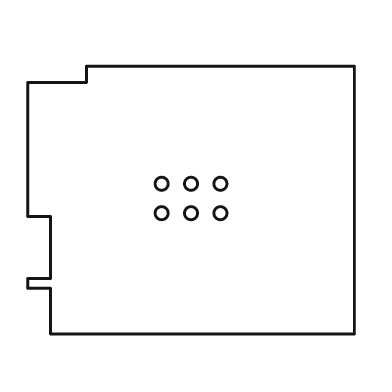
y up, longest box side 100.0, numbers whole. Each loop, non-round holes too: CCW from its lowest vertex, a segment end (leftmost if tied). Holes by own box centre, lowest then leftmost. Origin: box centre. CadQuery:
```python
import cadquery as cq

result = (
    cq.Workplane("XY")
    .moveTo(-43.0, -41.0)
    .lineTo(50.0, -41.0)
    .lineTo(50.0, 41.0)
    .lineTo(-32.0, 41.0)
    .lineTo(-32.0, 36.0)
    .lineTo(-50.0, 36.0)
    .lineTo(-50.0, -5.0)
    .lineTo(-43.0, -5.0)
    .lineTo(-43.0, -24.0)
    .lineTo(-50.0, -24.0)
    .lineTo(-50.0, -27.0)
    .lineTo(-43.0, -27.0)
    .close()
    .moveTo(-9.0, -4.0)
    .circle(2.0)
    .moveTo(0.0, -4.0)
    .circle(2.0)
    .moveTo(9.0, -4.0)
    .circle(2.0)
    .moveTo(-9.0, 5.0)
    .circle(2.0)
    .moveTo(0.0, 5.0)
    .circle(2.0)
    .moveTo(9.0, 5.0)
    .circle(2.0)
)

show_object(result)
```